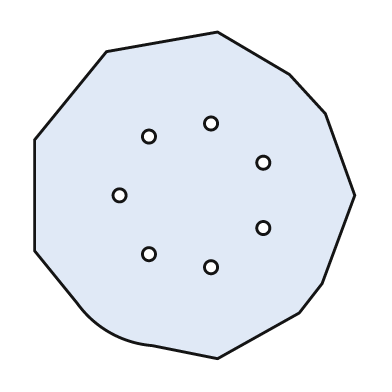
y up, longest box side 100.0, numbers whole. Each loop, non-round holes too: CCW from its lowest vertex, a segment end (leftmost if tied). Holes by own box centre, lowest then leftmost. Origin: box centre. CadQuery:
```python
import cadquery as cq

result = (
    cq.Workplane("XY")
    .moveTo(7.0, -50.0)
    .lineTo(32.0, -36.0)
    .lineTo(39.0, -27.0)
    .lineTo(49.0, 0.0)
    .lineTo(40.0, 25.0)
    .lineTo(29.0, 37.0)
    .lineTo(7.0, 50.0)
    .lineTo(-27.0, 44.0)
    .lineTo(-49.0, 17.0)
    .lineTo(-49.0, -17.0)
    .lineTo(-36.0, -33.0)
    .threePointArc((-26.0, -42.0), (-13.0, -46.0))
    .close()
    .moveTo(5.0, -22.0)
    .circle(2.0)
    .moveTo(-14.0, -18.0)
    .circle(2.0)
    .moveTo(21.0, -10.0)
    .circle(2.0)
    .moveTo(-23.0, 0.0)
    .circle(2.0)
    .moveTo(21.0, 10.0)
    .circle(2.0)
    .moveTo(-14.0, 18.0)
    .circle(2.0)
    .moveTo(5.0, 22.0)
    .circle(2.0)
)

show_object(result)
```